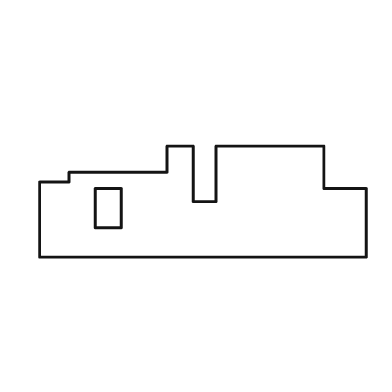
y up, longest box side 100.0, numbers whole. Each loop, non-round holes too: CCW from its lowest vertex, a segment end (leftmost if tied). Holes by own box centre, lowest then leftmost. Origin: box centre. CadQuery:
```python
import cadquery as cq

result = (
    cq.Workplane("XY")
    .moveTo(-50.0, -17.0)
    .lineTo(50.0, -17.0)
    .lineTo(50.0, 4.0)
    .lineTo(37.0, 4.0)
    .lineTo(37.0, 17.0)
    .lineTo(4.0, 17.0)
    .lineTo(4.0, 0.0)
    .lineTo(-3.0, 0.0)
    .lineTo(-3.0, 17.0)
    .lineTo(-11.0, 17.0)
    .lineTo(-11.0, 9.0)
    .lineTo(-41.0, 9.0)
    .lineTo(-41.0, 6.0)
    .lineTo(-50.0, 6.0)
    .close()
    .moveTo(-33.0, -8.0)
    .lineTo(-25.0, -8.0)
    .lineTo(-25.0, 4.0)
    .lineTo(-33.0, 4.0)
    .close()
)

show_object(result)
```